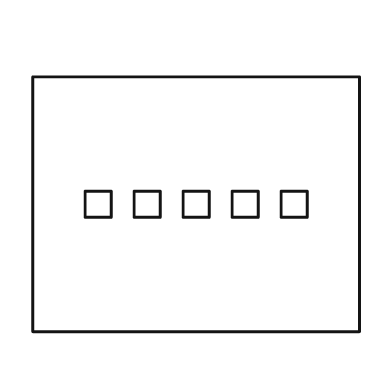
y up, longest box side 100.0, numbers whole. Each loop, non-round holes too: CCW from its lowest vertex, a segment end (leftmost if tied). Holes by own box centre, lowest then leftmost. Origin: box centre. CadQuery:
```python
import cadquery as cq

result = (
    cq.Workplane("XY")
    .moveTo(-50.0, -39.0)
    .lineTo(50.0, -39.0)
    .lineTo(50.0, 39.0)
    .lineTo(-50.0, 39.0)
    .close()
    .moveTo(-34.0, -4.0)
    .lineTo(-26.0, -4.0)
    .lineTo(-26.0, 4.0)
    .lineTo(-34.0, 4.0)
    .close()
    .moveTo(-19.0, -4.0)
    .lineTo(-11.0, -4.0)
    .lineTo(-11.0, 4.0)
    .lineTo(-19.0, 4.0)
    .close()
    .moveTo(-4.0, -4.0)
    .lineTo(4.0, -4.0)
    .lineTo(4.0, 4.0)
    .lineTo(-4.0, 4.0)
    .close()
    .moveTo(11.0, -4.0)
    .lineTo(19.0, -4.0)
    .lineTo(19.0, 4.0)
    .lineTo(11.0, 4.0)
    .close()
    .moveTo(26.0, -4.0)
    .lineTo(34.0, -4.0)
    .lineTo(34.0, 4.0)
    .lineTo(26.0, 4.0)
    .close()
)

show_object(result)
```